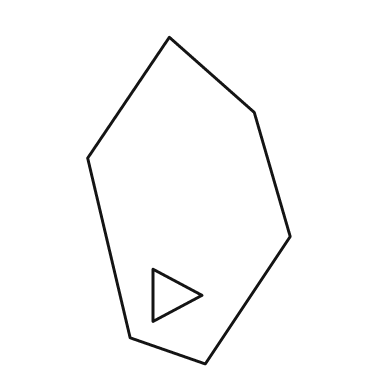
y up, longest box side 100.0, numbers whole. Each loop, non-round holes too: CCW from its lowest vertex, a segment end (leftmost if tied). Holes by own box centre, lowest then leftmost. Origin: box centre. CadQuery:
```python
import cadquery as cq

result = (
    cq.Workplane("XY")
    .moveTo(5.0, -50.0)
    .lineTo(31.0, -11.0)
    .lineTo(20.0, 27.0)
    .lineTo(-6.0, 50.0)
    .lineTo(-31.0, 13.0)
    .lineTo(-18.0, -42.0)
    .close()
    .moveTo(-11.0, -37.0)
    .lineTo(4.0, -29.0)
    .lineTo(-11.0, -21.0)
    .close()
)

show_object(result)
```